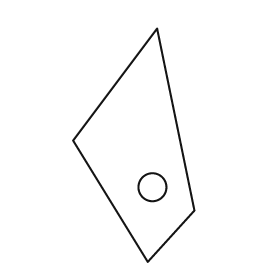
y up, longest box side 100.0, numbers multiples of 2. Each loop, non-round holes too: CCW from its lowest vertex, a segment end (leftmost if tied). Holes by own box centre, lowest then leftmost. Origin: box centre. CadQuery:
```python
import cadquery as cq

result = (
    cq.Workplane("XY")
    .moveTo(6.0, -50.0)
    .lineTo(26.0, -28.0)
    .lineTo(10.0, 50.0)
    .lineTo(-26.0, 2.0)
    .close()
    .moveTo(8.0, -18.0)
    .circle(6.0)
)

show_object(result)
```